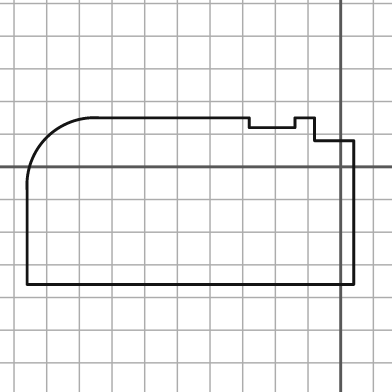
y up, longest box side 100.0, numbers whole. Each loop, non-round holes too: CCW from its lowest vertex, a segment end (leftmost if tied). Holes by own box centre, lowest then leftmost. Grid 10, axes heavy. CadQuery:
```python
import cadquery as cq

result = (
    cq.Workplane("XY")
    .moveTo(-96.0, -36.0)
    .lineTo(4.0, -36.0)
    .lineTo(4.0, 8.0)
    .lineTo(-8.0, 8.0)
    .lineTo(-8.0, 15.0)
    .lineTo(-14.0, 15.0)
    .lineTo(-14.0, 12.0)
    .lineTo(-28.0, 12.0)
    .lineTo(-28.0, 15.0)
    .lineTo(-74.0, 15.0)
    .threePointArc((-90.0, 9.0), (-96.0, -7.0))
    .close()
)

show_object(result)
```